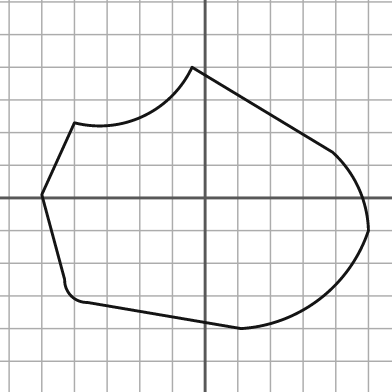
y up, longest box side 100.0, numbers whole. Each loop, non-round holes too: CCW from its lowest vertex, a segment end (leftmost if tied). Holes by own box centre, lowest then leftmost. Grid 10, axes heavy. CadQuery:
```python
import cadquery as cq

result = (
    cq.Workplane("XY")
    .moveTo(11.0, -40.0)
    .threePointArc((35.0, -31.0), (50.0, -10.0))
    .threePointArc((47.0, 3.0), (39.0, 14.0))
    .lineTo(-4.0, 40.0)
    .threePointArc((-19.0, 25.0), (-40.0, 23.0))
    .lineTo(-50.0, 1.0)
    .lineTo(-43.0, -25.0)
    .threePointArc((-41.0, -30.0), (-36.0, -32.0))
    .close()
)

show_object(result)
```